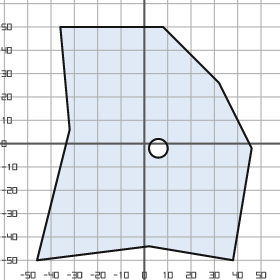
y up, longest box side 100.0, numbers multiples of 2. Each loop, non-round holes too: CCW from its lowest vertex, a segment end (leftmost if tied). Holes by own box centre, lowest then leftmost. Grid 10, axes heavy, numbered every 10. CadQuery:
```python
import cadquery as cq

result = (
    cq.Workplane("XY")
    .moveTo(-46.0, -50.0)
    .lineTo(2.0, -44.0)
    .lineTo(38.0, -50.0)
    .lineTo(46.0, -2.0)
    .lineTo(32.0, 26.0)
    .lineTo(8.0, 50.0)
    .lineTo(-36.0, 50.0)
    .lineTo(-32.0, 6.0)
    .close()
    .moveTo(6.0, -2.0)
    .circle(4.0)
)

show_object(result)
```